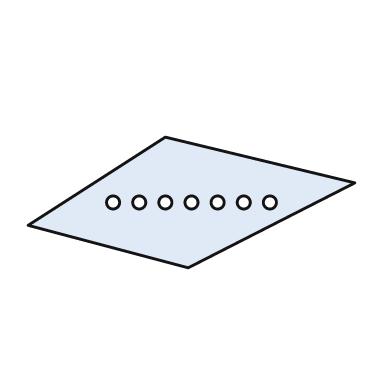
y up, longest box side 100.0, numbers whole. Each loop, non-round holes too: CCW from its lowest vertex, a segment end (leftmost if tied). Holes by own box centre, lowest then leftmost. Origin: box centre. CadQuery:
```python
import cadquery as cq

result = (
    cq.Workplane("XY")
    .moveTo(-1.0, -20.0)
    .lineTo(50.0, 6.0)
    .lineTo(-8.0, 20.0)
    .lineTo(-50.0, -7.0)
    .close()
    .moveTo(-24.0, 0.0)
    .circle(2.0)
    .moveTo(-16.0, 0.0)
    .circle(2.0)
    .moveTo(-8.0, 0.0)
    .circle(2.0)
    .moveTo(0.0, 0.0)
    .circle(2.0)
    .moveTo(8.0, 0.0)
    .circle(2.0)
    .moveTo(16.0, 0.0)
    .circle(2.0)
    .moveTo(24.0, 0.0)
    .circle(2.0)
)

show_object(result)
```